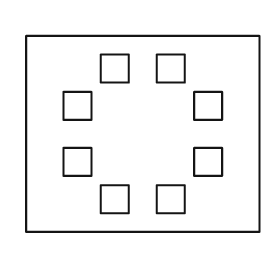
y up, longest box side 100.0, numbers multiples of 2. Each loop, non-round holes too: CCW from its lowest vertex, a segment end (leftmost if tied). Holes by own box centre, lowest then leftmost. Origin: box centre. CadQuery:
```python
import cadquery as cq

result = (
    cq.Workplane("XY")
    .moveTo(-50.0, -42.0)
    .lineTo(50.0, -42.0)
    .lineTo(50.0, 42.0)
    .lineTo(-50.0, 42.0)
    .close()
    .moveTo(-18.0, -34.0)
    .lineTo(-6.0, -34.0)
    .lineTo(-6.0, -22.0)
    .lineTo(-18.0, -22.0)
    .close()
    .moveTo(6.0, -34.0)
    .lineTo(18.0, -34.0)
    .lineTo(18.0, -22.0)
    .lineTo(6.0, -22.0)
    .close()
    .moveTo(-34.0, -18.0)
    .lineTo(-22.0, -18.0)
    .lineTo(-22.0, -6.0)
    .lineTo(-34.0, -6.0)
    .close()
    .moveTo(22.0, -18.0)
    .lineTo(34.0, -18.0)
    .lineTo(34.0, -6.0)
    .lineTo(22.0, -6.0)
    .close()
    .moveTo(-34.0, 6.0)
    .lineTo(-22.0, 6.0)
    .lineTo(-22.0, 18.0)
    .lineTo(-34.0, 18.0)
    .close()
    .moveTo(22.0, 6.0)
    .lineTo(34.0, 6.0)
    .lineTo(34.0, 18.0)
    .lineTo(22.0, 18.0)
    .close()
    .moveTo(-18.0, 22.0)
    .lineTo(-6.0, 22.0)
    .lineTo(-6.0, 34.0)
    .lineTo(-18.0, 34.0)
    .close()
    .moveTo(6.0, 22.0)
    .lineTo(18.0, 22.0)
    .lineTo(18.0, 34.0)
    .lineTo(6.0, 34.0)
    .close()
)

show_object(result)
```